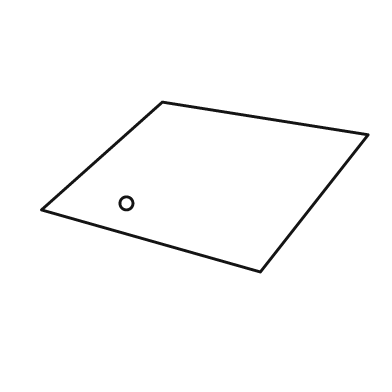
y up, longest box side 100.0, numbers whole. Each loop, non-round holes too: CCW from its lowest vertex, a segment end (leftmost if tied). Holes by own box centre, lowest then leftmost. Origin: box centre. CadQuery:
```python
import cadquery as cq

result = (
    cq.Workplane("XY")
    .moveTo(17.0, -26.0)
    .lineTo(50.0, 16.0)
    .lineTo(-13.0, 26.0)
    .lineTo(-50.0, -7.0)
    .close()
    .moveTo(-24.0, -5.0)
    .circle(2.0)
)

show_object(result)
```